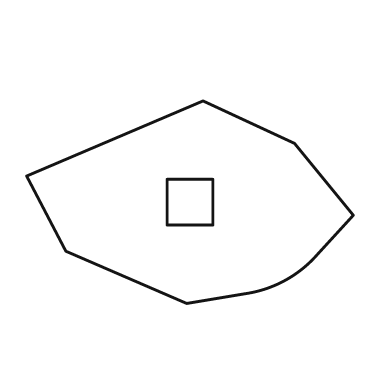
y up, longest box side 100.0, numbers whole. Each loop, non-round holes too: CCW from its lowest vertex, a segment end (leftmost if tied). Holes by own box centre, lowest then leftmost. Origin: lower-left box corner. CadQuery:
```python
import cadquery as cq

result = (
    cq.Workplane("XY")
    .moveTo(49.0, 0.0)
    .lineTo(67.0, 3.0)
    .threePointArc((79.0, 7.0), (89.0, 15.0))
    .lineTo(100.0, 27.0)
    .lineTo(82.0, 49.0)
    .lineTo(54.0, 62.0)
    .lineTo(0.0, 39.0)
    .lineTo(12.0, 16.0)
    .close()
    .moveTo(43.0, 24.0)
    .lineTo(57.0, 24.0)
    .lineTo(57.0, 38.0)
    .lineTo(43.0, 38.0)
    .close()
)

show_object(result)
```